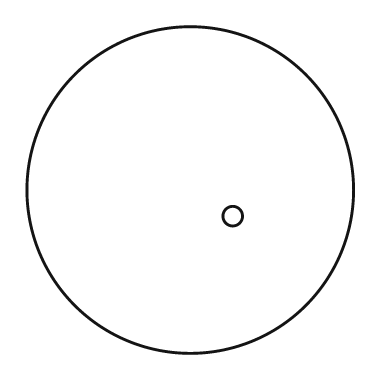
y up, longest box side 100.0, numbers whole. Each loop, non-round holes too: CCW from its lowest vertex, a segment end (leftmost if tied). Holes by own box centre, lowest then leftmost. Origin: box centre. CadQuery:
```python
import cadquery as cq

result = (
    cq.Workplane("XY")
    .moveTo(0.0, 0.0)
    .circle(50.0)
    .moveTo(13.0, -8.0)
    .circle(3.0)
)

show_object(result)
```